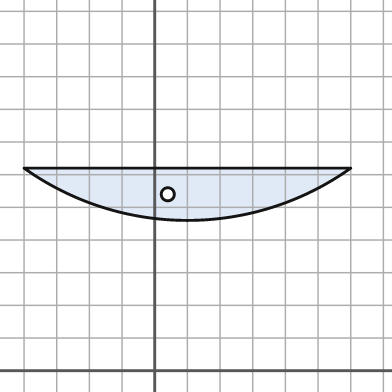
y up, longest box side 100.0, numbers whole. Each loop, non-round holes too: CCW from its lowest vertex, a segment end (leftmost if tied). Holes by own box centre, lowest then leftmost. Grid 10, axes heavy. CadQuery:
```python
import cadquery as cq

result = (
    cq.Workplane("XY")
    .moveTo(-40.0, 62.0)
    .threePointArc((10.0, 46.0), (60.0, 62.0))
    .close()
    .moveTo(4.0, 54.0)
    .circle(2.0)
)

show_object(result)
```